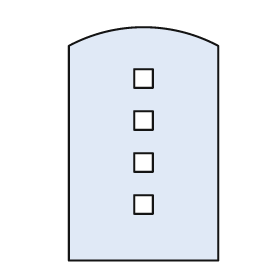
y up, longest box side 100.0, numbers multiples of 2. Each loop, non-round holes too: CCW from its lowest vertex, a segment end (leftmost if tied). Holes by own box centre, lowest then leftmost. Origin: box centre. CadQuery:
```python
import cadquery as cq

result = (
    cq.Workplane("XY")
    .moveTo(-32.0, -50.0)
    .lineTo(32.0, -50.0)
    .lineTo(32.0, 42.0)
    .threePointArc((0.0, 50.0), (-32.0, 42.0))
    .close()
    .moveTo(-4.0, -30.0)
    .lineTo(4.0, -30.0)
    .lineTo(4.0, -22.0)
    .lineTo(-4.0, -22.0)
    .close()
    .moveTo(-4.0, -12.0)
    .lineTo(4.0, -12.0)
    .lineTo(4.0, -4.0)
    .lineTo(-4.0, -4.0)
    .close()
    .moveTo(-4.0, 6.0)
    .lineTo(4.0, 6.0)
    .lineTo(4.0, 14.0)
    .lineTo(-4.0, 14.0)
    .close()
    .moveTo(-4.0, 24.0)
    .lineTo(4.0, 24.0)
    .lineTo(4.0, 32.0)
    .lineTo(-4.0, 32.0)
    .close()
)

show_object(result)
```